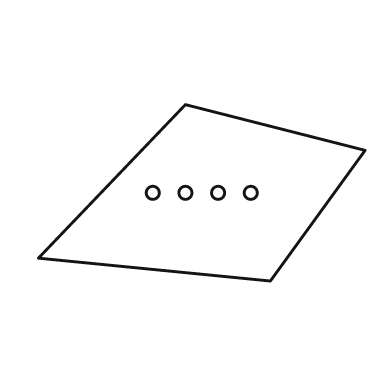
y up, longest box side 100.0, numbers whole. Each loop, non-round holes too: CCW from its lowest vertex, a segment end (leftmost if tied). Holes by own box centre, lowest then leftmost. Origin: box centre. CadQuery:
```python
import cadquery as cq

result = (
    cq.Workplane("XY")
    .moveTo(21.0, -27.0)
    .lineTo(50.0, 13.0)
    .lineTo(-5.0, 27.0)
    .lineTo(-50.0, -20.0)
    .close()
    .moveTo(-15.0, 0.0)
    .circle(2.0)
    .moveTo(-5.0, 0.0)
    .circle(2.0)
    .moveTo(5.0, 0.0)
    .circle(2.0)
    .moveTo(15.0, 0.0)
    .circle(2.0)
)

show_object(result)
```